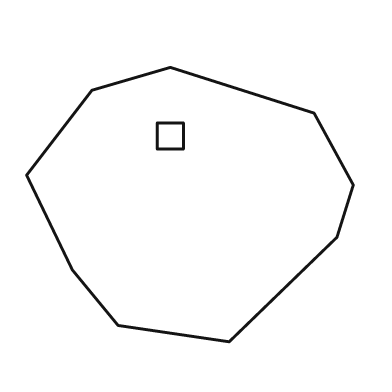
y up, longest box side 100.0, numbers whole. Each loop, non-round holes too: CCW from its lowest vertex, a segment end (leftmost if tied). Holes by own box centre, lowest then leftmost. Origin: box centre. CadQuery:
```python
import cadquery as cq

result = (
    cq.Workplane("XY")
    .moveTo(12.0, -42.0)
    .lineTo(45.0, -10.0)
    .lineTo(50.0, 6.0)
    .lineTo(38.0, 28.0)
    .lineTo(-6.0, 42.0)
    .lineTo(-30.0, 35.0)
    .lineTo(-50.0, 9.0)
    .lineTo(-36.0, -20.0)
    .lineTo(-22.0, -37.0)
    .close()
    .moveTo(-10.0, 17.0)
    .lineTo(-2.0, 17.0)
    .lineTo(-2.0, 25.0)
    .lineTo(-10.0, 25.0)
    .close()
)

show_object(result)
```